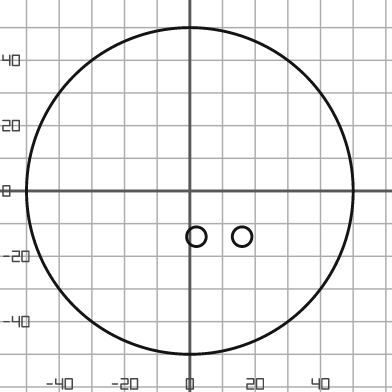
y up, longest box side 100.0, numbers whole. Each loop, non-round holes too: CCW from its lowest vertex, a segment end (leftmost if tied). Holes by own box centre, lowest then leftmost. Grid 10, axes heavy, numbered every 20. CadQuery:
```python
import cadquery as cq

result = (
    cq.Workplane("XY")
    .moveTo(0.0, 0.0)
    .circle(50.0)
    .moveTo(2.0, -14.0)
    .circle(3.0)
    .moveTo(16.0, -14.0)
    .circle(3.0)
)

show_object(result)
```